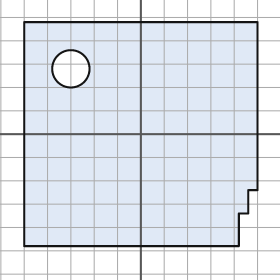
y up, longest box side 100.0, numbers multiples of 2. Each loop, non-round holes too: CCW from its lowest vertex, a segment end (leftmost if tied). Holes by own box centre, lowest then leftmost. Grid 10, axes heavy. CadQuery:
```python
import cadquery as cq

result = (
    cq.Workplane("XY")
    .moveTo(-50.0, -48.0)
    .lineTo(42.0, -48.0)
    .lineTo(42.0, -34.0)
    .lineTo(46.0, -34.0)
    .lineTo(46.0, -24.0)
    .lineTo(50.0, -24.0)
    .lineTo(50.0, 48.0)
    .lineTo(-50.0, 48.0)
    .close()
    .moveTo(-30.0, 28.0)
    .circle(8.0)
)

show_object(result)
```